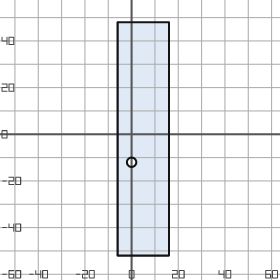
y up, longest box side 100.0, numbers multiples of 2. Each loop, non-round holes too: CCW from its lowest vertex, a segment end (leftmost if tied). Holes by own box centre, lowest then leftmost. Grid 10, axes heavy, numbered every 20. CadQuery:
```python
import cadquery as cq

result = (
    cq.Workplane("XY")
    .moveTo(-6.0, -52.0)
    .lineTo(16.0, -52.0)
    .lineTo(16.0, 48.0)
    .lineTo(-6.0, 48.0)
    .close()
    .moveTo(0.0, -12.0)
    .circle(2.0)
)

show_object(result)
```